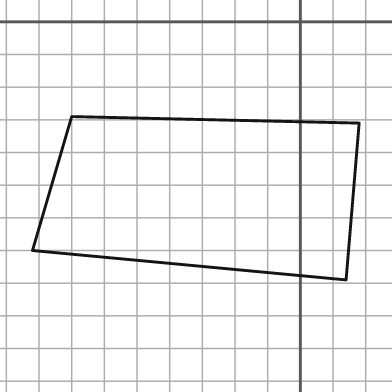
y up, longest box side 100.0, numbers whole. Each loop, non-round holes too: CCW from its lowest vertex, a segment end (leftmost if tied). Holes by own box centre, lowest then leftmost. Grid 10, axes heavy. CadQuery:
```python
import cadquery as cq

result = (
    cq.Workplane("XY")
    .moveTo(14.0, -79.0)
    .lineTo(18.0, -31.0)
    .lineTo(-70.0, -29.0)
    .lineTo(-82.0, -70.0)
    .close()
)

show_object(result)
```